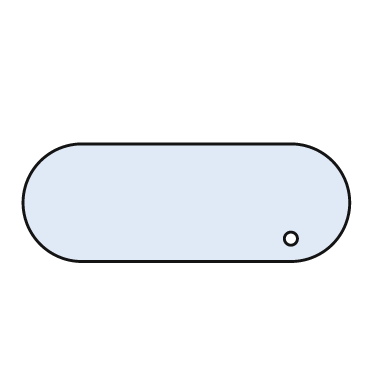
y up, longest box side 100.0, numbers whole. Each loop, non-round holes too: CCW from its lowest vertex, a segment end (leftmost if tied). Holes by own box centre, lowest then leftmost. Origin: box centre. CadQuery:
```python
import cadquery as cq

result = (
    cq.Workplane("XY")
    .moveTo(-32.0, -18.0)
    .lineTo(32.0, -18.0)
    .threePointArc((50.0, 0.0), (32.0, 18.0))
    .lineTo(-32.0, 18.0)
    .threePointArc((-50.0, 0.0), (-32.0, -18.0))
    .close()
    .moveTo(32.0, -11.0)
    .circle(2.0)
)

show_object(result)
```